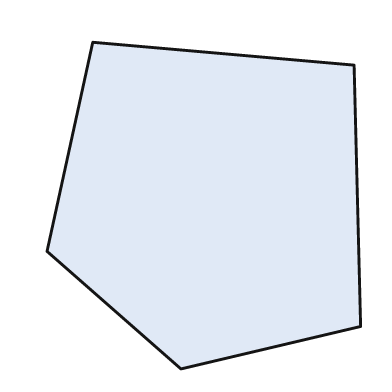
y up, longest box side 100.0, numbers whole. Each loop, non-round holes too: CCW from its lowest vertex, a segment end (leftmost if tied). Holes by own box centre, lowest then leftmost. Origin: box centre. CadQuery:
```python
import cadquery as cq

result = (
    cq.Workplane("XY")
    .moveTo(-7.0, -50.0)
    .lineTo(48.0, -37.0)
    .lineTo(46.0, 43.0)
    .lineTo(-34.0, 50.0)
    .lineTo(-48.0, -14.0)
    .close()
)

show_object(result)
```